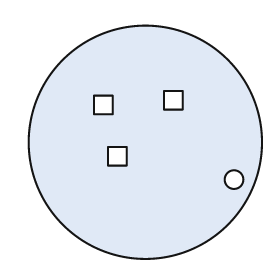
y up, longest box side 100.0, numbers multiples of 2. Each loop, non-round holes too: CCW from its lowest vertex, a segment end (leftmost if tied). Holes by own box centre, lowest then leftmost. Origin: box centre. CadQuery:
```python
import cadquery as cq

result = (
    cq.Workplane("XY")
    .moveTo(0.0, 0.0)
    .circle(50.0)
    .moveTo(38.0, -16.0)
    .circle(4.0)
    .moveTo(-16.0, -10.0)
    .lineTo(-8.0, -10.0)
    .lineTo(-8.0, -2.0)
    .lineTo(-16.0, -2.0)
    .close()
    .moveTo(-22.0, 12.0)
    .lineTo(-14.0, 12.0)
    .lineTo(-14.0, 20.0)
    .lineTo(-22.0, 20.0)
    .close()
    .moveTo(8.0, 14.0)
    .lineTo(16.0, 14.0)
    .lineTo(16.0, 22.0)
    .lineTo(8.0, 22.0)
    .close()
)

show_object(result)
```